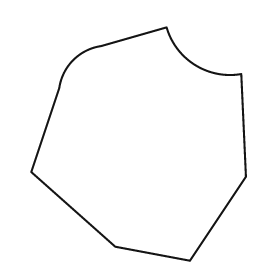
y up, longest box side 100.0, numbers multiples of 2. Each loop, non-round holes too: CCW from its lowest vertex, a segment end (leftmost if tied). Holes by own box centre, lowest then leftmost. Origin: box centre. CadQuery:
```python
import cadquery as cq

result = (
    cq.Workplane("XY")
    .moveTo(22.0, -50.0)
    .lineTo(46.0, -14.0)
    .lineTo(44.0, 30.0)
    .threePointArc((24.0, 34.0), (12.0, 50.0))
    .lineTo(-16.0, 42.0)
    .threePointArc((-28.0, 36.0), (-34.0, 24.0))
    .lineTo(-46.0, -12.0)
    .lineTo(-10.0, -44.0)
    .close()
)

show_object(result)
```